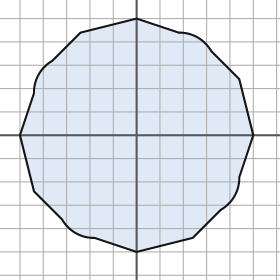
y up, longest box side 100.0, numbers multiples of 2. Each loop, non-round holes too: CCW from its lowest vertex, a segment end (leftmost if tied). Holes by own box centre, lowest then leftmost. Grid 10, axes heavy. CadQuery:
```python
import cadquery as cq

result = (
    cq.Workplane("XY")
    .moveTo(0.0, -50.0)
    .lineTo(24.0, -44.0)
    .lineTo(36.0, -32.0)
    .threePointArc((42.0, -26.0), (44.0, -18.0))
    .lineTo(50.0, 0.0)
    .lineTo(44.0, 24.0)
    .lineTo(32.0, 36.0)
    .threePointArc((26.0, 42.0), (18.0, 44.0))
    .lineTo(0.0, 50.0)
    .lineTo(-24.0, 44.0)
    .lineTo(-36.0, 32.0)
    .threePointArc((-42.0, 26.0), (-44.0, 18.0))
    .lineTo(-50.0, 0.0)
    .lineTo(-44.0, -24.0)
    .lineTo(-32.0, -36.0)
    .threePointArc((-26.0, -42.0), (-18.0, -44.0))
    .close()
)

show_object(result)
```